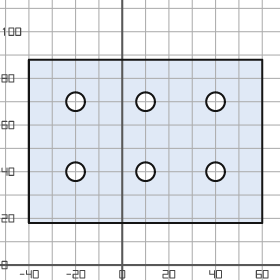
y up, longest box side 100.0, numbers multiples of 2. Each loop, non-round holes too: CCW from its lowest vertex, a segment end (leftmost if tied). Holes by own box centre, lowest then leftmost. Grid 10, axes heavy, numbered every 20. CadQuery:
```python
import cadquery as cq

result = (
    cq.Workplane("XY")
    .moveTo(-40.0, 18.0)
    .lineTo(60.0, 18.0)
    .lineTo(60.0, 88.0)
    .lineTo(-40.0, 88.0)
    .close()
    .moveTo(-20.0, 40.0)
    .circle(4.0)
    .moveTo(10.0, 40.0)
    .circle(4.0)
    .moveTo(40.0, 40.0)
    .circle(4.0)
    .moveTo(-20.0, 70.0)
    .circle(4.0)
    .moveTo(10.0, 70.0)
    .circle(4.0)
    .moveTo(40.0, 70.0)
    .circle(4.0)
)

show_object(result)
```